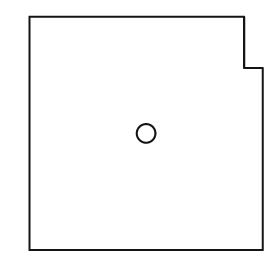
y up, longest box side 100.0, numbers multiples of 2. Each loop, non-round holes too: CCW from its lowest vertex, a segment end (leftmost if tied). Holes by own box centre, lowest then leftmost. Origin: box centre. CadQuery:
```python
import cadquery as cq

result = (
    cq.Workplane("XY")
    .moveTo(-50.0, -50.0)
    .lineTo(50.0, -50.0)
    .lineTo(50.0, 28.0)
    .lineTo(42.0, 28.0)
    .lineTo(42.0, 50.0)
    .lineTo(-50.0, 50.0)
    .close()
    .moveTo(0.0, 0.0)
    .circle(4.0)
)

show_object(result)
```